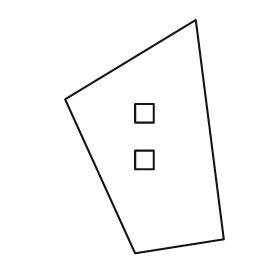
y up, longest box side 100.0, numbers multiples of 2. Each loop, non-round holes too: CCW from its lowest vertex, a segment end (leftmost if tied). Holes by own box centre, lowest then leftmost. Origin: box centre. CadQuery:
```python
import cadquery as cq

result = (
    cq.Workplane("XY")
    .moveTo(-4.0, -50.0)
    .lineTo(34.0, -44.0)
    .lineTo(22.0, 50.0)
    .lineTo(-34.0, 16.0)
    .close()
    .moveTo(-4.0, -14.0)
    .lineTo(4.0, -14.0)
    .lineTo(4.0, -6.0)
    .lineTo(-4.0, -6.0)
    .close()
    .moveTo(-4.0, 6.0)
    .lineTo(4.0, 6.0)
    .lineTo(4.0, 14.0)
    .lineTo(-4.0, 14.0)
    .close()
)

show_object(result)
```